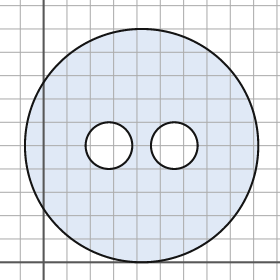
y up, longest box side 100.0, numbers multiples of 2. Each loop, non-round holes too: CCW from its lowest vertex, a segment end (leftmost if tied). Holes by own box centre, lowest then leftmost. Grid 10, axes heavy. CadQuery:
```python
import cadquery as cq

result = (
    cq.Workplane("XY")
    .moveTo(42.0, 50.0)
    .circle(50.0)
    .moveTo(28.0, 50.0)
    .circle(10.0)
    .moveTo(56.0, 50.0)
    .circle(10.0)
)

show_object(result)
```